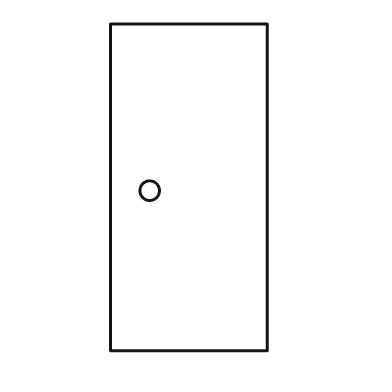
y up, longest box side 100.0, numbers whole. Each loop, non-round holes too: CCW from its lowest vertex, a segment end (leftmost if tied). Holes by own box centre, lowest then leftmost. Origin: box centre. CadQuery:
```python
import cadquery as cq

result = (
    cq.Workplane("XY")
    .moveTo(-24.0, -50.0)
    .lineTo(24.0, -50.0)
    .lineTo(24.0, 50.0)
    .lineTo(-24.0, 50.0)
    .close()
    .moveTo(-12.0, -1.0)
    .circle(3.0)
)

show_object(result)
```